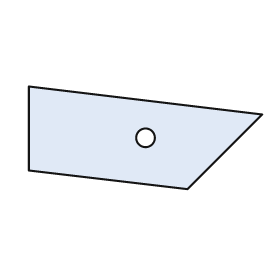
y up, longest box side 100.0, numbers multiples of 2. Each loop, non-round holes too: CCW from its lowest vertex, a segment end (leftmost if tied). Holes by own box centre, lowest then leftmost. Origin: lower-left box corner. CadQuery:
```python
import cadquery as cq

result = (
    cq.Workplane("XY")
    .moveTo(68.0, 0.0)
    .lineTo(100.0, 32.0)
    .lineTo(0.0, 44.0)
    .lineTo(0.0, 8.0)
    .close()
    .moveTo(50.0, 22.0)
    .circle(4.0)
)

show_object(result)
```